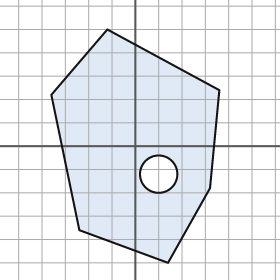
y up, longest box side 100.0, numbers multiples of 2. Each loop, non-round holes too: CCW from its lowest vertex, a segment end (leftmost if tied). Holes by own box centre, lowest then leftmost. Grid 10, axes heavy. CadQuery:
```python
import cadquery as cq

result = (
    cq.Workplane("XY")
    .moveTo(14.0, -50.0)
    .lineTo(32.0, -18.0)
    .lineTo(36.0, 24.0)
    .lineTo(-12.0, 50.0)
    .lineTo(-36.0, 22.0)
    .lineTo(-24.0, -36.0)
    .close()
    .moveTo(10.0, -12.0)
    .circle(8.0)
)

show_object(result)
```